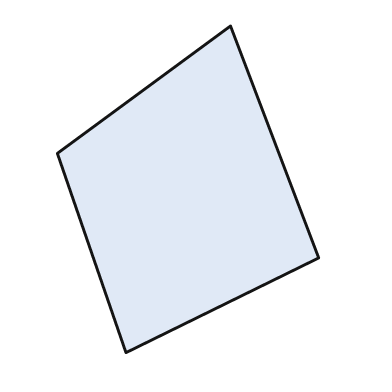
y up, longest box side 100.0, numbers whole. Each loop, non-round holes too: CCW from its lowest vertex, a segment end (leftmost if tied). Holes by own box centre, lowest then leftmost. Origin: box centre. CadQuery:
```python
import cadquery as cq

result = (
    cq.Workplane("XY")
    .moveTo(-19.0, -50.0)
    .lineTo(40.0, -21.0)
    .lineTo(13.0, 50.0)
    .lineTo(-40.0, 11.0)
    .close()
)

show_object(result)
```